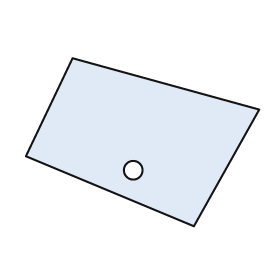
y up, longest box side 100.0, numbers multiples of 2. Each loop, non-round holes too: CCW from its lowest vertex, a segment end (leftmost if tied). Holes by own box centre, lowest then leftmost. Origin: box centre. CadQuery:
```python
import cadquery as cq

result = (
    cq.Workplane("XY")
    .moveTo(22.0, -36.0)
    .lineTo(50.0, 14.0)
    .lineTo(-30.0, 36.0)
    .lineTo(-50.0, -6.0)
    .close()
    .moveTo(-4.0, -12.0)
    .circle(4.0)
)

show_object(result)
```